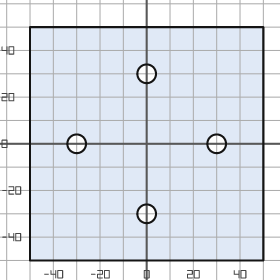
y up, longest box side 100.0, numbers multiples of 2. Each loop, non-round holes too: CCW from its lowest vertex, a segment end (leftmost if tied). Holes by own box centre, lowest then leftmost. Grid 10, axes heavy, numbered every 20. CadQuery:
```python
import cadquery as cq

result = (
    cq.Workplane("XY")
    .moveTo(-50.0, -50.0)
    .lineTo(50.0, -50.0)
    .lineTo(50.0, 50.0)
    .lineTo(-50.0, 50.0)
    .close()
    .moveTo(0.0, -30.0)
    .circle(4.0)
    .moveTo(-30.0, 0.0)
    .circle(4.0)
    .moveTo(30.0, 0.0)
    .circle(4.0)
    .moveTo(0.0, 30.0)
    .circle(4.0)
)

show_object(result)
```